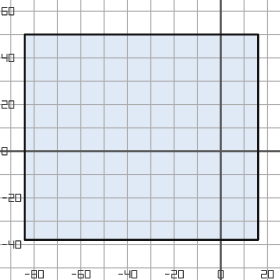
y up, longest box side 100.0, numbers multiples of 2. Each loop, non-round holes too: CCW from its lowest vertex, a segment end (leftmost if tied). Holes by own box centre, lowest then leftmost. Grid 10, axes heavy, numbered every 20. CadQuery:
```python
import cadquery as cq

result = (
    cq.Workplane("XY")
    .moveTo(-84.0, -38.0)
    .lineTo(16.0, -38.0)
    .lineTo(16.0, 50.0)
    .lineTo(-84.0, 50.0)
    .close()
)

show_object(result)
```